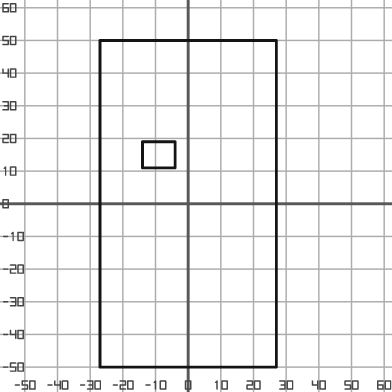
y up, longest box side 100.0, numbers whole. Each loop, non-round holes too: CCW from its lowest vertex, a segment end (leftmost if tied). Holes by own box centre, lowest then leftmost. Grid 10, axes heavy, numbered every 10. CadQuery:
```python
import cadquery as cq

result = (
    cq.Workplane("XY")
    .moveTo(-27.0, -50.0)
    .lineTo(27.0, -50.0)
    .lineTo(27.0, 50.0)
    .lineTo(-27.0, 50.0)
    .close()
    .moveTo(-14.0, 11.0)
    .lineTo(-4.0, 11.0)
    .lineTo(-4.0, 19.0)
    .lineTo(-14.0, 19.0)
    .close()
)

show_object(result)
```